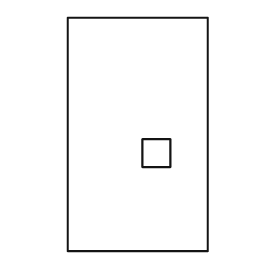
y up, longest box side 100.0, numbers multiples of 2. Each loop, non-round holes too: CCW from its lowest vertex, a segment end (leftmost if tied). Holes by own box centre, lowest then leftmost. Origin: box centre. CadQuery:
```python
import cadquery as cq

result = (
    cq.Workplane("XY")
    .moveTo(-30.0, -50.0)
    .lineTo(30.0, -50.0)
    .lineTo(30.0, 50.0)
    .lineTo(-30.0, 50.0)
    .close()
    .moveTo(2.0, -14.0)
    .lineTo(14.0, -14.0)
    .lineTo(14.0, -2.0)
    .lineTo(2.0, -2.0)
    .close()
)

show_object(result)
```